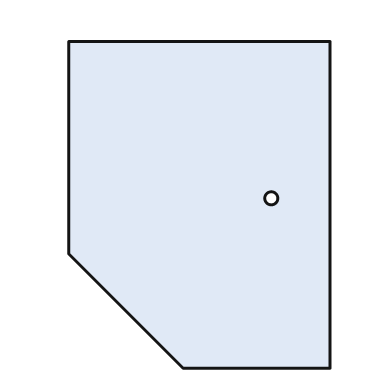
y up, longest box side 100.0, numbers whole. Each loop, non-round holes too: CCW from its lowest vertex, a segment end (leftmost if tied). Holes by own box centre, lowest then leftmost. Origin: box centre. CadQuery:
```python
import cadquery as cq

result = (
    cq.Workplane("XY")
    .moveTo(-5.0, -50.0)
    .lineTo(40.0, -50.0)
    .lineTo(40.0, 50.0)
    .lineTo(-40.0, 50.0)
    .lineTo(-40.0, -15.0)
    .close()
    .moveTo(22.0, 2.0)
    .circle(2.0)
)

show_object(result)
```